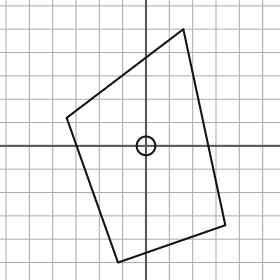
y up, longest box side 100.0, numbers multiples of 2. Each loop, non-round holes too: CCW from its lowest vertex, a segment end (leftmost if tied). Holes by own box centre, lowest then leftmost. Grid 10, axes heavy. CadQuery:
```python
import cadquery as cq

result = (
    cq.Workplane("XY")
    .moveTo(-12.0, -50.0)
    .lineTo(34.0, -34.0)
    .lineTo(16.0, 50.0)
    .lineTo(-34.0, 12.0)
    .close()
    .moveTo(0.0, 0.0)
    .circle(4.0)
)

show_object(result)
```